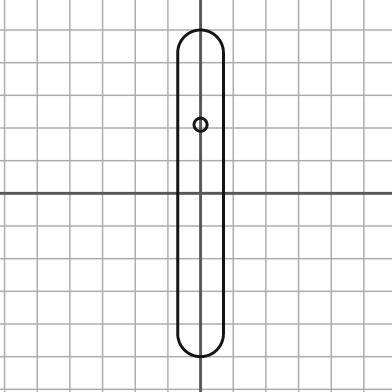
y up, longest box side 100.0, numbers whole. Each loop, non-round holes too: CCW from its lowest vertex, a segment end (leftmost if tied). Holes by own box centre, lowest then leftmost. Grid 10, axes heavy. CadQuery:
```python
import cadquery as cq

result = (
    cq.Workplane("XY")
    .moveTo(-7.0, -43.0)
    .threePointArc((0.0, -50.0), (7.0, -43.0))
    .lineTo(7.0, 43.0)
    .threePointArc((0.0, 50.0), (-7.0, 43.0))
    .close()
    .moveTo(0.0, 21.0)
    .circle(2.0)
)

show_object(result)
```